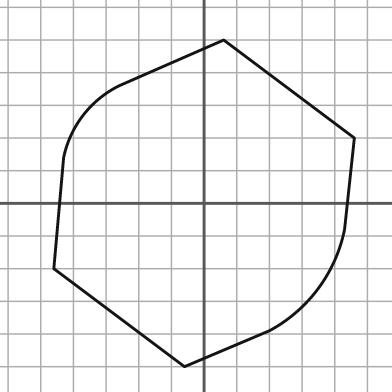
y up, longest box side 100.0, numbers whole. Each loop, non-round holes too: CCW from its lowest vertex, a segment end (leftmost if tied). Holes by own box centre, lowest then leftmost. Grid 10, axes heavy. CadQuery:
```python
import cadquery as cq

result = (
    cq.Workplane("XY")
    .moveTo(-6.0, -50.0)
    .lineTo(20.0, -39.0)
    .threePointArc((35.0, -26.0), (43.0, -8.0))
    .lineTo(46.0, 20.0)
    .lineTo(6.0, 50.0)
    .lineTo(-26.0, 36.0)
    .threePointArc((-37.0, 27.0), (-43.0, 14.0))
    .lineTo(-46.0, -20.0)
    .close()
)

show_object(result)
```